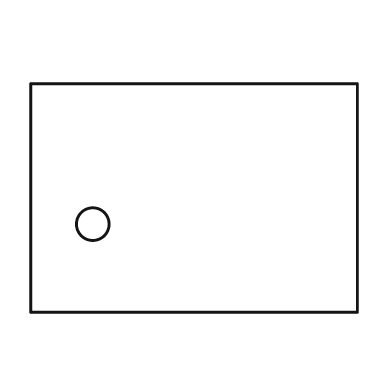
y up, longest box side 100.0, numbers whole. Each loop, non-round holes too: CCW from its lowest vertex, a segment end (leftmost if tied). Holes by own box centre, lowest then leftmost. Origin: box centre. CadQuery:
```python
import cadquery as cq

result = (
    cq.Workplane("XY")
    .moveTo(-50.0, -35.0)
    .lineTo(50.0, -35.0)
    .lineTo(50.0, 35.0)
    .lineTo(-50.0, 35.0)
    .close()
    .moveTo(-31.0, -8.0)
    .circle(5.0)
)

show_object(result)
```